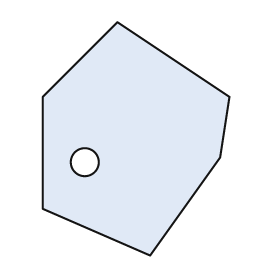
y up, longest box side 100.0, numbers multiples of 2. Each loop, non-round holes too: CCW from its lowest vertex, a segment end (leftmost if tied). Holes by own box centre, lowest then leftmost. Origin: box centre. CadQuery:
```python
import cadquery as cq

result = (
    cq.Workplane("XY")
    .moveTo(6.0, -50.0)
    .lineTo(36.0, -8.0)
    .lineTo(40.0, 18.0)
    .lineTo(-8.0, 50.0)
    .lineTo(-40.0, 18.0)
    .lineTo(-40.0, -30.0)
    .close()
    .moveTo(-22.0, -10.0)
    .circle(6.0)
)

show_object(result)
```